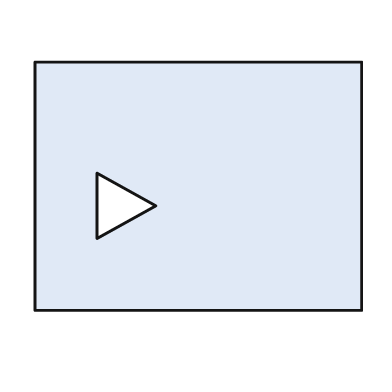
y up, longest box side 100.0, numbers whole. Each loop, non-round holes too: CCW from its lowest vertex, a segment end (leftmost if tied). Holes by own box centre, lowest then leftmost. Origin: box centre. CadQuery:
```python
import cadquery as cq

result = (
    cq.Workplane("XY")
    .moveTo(-50.0, -38.0)
    .lineTo(50.0, -38.0)
    .lineTo(50.0, 38.0)
    .lineTo(-50.0, 38.0)
    .close()
    .moveTo(-31.0, -16.0)
    .lineTo(-13.0, -6.0)
    .lineTo(-31.0, 4.0)
    .close()
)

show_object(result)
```